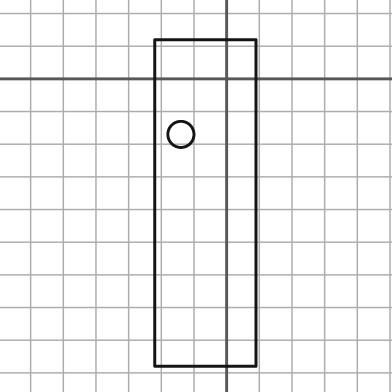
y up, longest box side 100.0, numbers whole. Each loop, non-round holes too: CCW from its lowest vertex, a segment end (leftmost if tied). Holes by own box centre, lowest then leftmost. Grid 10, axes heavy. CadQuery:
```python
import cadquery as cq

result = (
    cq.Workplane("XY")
    .moveTo(-22.0, -88.0)
    .lineTo(9.0, -88.0)
    .lineTo(9.0, 12.0)
    .lineTo(-22.0, 12.0)
    .close()
    .moveTo(-14.0, -17.0)
    .circle(4.0)
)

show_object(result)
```